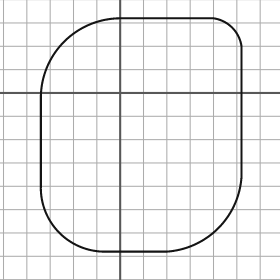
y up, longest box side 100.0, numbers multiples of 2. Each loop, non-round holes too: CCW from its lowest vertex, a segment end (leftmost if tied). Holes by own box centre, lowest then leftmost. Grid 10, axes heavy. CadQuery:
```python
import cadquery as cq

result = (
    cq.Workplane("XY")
    .moveTo(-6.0, -68.0)
    .lineTo(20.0, -68.0)
    .threePointArc((42.0, -58.0), (52.0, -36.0))
    .lineTo(52.0, 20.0)
    .threePointArc((48.0, 28.0), (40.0, 32.0))
    .lineTo(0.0, 32.0)
    .threePointArc((-24.0, 22.0), (-34.0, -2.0))
    .lineTo(-34.0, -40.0)
    .threePointArc((-26.0, -60.0), (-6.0, -68.0))
    .close()
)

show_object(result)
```